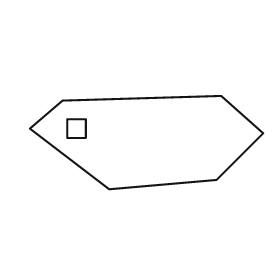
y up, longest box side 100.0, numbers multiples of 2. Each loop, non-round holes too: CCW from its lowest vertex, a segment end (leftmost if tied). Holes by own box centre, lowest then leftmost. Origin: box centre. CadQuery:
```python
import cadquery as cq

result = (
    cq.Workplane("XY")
    .moveTo(-16.0, -20.0)
    .lineTo(30.0, -16.0)
    .lineTo(50.0, 4.0)
    .lineTo(32.0, 20.0)
    .lineTo(-36.0, 18.0)
    .lineTo(-50.0, 6.0)
    .close()
    .moveTo(-34.0, 2.0)
    .lineTo(-26.0, 2.0)
    .lineTo(-26.0, 10.0)
    .lineTo(-34.0, 10.0)
    .close()
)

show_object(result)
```